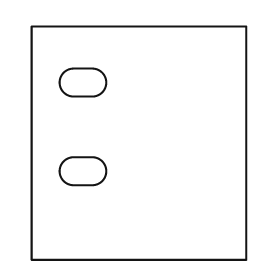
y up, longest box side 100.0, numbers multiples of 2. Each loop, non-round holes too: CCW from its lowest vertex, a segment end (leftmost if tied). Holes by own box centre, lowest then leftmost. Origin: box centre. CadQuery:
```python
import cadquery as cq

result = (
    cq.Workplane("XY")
    .moveTo(-46.0, -50.0)
    .lineTo(46.0, -50.0)
    .lineTo(46.0, 50.0)
    .lineTo(-46.0, 50.0)
    .close()
    .moveTo(-28.0, -18.0)
    .lineTo(-20.0, -18.0)
    .threePointArc((-14.0, -12.0), (-20.0, -6.0))
    .lineTo(-28.0, -6.0)
    .threePointArc((-34.0, -12.0), (-28.0, -18.0))
    .close()
    .moveTo(-28.0, 20.0)
    .lineTo(-20.0, 20.0)
    .threePointArc((-14.0, 26.0), (-20.0, 32.0))
    .lineTo(-28.0, 32.0)
    .threePointArc((-34.0, 26.0), (-28.0, 20.0))
    .close()
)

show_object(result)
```